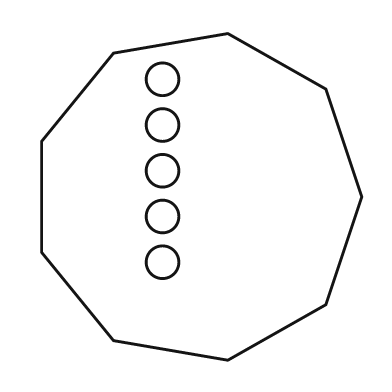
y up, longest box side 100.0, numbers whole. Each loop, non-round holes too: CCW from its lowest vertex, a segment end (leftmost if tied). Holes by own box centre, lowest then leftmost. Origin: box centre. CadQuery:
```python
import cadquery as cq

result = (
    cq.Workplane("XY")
    .moveTo(8.0, -50.0)
    .lineTo(38.0, -33.0)
    .lineTo(49.0, 0.0)
    .lineTo(38.0, 33.0)
    .lineTo(8.0, 50.0)
    .lineTo(-27.0, 44.0)
    .lineTo(-49.0, 17.0)
    .lineTo(-49.0, -17.0)
    .lineTo(-27.0, -44.0)
    .close()
    .moveTo(-12.0, -20.0)
    .circle(5.0)
    .moveTo(-12.0, -6.0)
    .circle(5.0)
    .moveTo(-12.0, 8.0)
    .circle(5.0)
    .moveTo(-12.0, 22.0)
    .circle(5.0)
    .moveTo(-12.0, 36.0)
    .circle(5.0)
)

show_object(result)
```